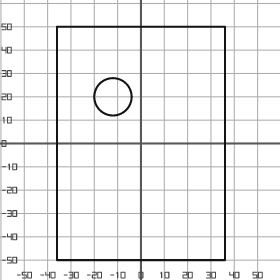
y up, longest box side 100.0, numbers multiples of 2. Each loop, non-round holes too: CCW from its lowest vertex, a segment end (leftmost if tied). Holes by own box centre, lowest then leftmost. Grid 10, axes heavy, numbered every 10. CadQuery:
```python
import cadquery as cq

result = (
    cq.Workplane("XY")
    .moveTo(-36.0, -50.0)
    .lineTo(36.0, -50.0)
    .lineTo(36.0, 50.0)
    .lineTo(-36.0, 50.0)
    .close()
    .moveTo(-12.0, 20.0)
    .circle(8.0)
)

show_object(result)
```